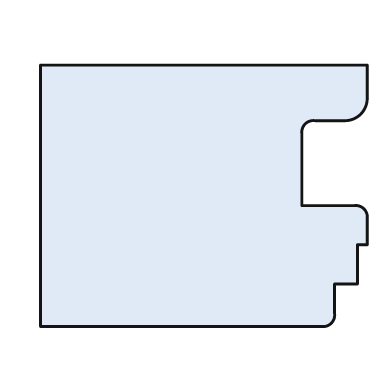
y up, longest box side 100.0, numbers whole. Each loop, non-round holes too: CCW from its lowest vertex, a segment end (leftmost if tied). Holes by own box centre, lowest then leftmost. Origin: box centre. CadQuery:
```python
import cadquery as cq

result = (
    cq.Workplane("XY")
    .moveTo(-50.0, -40.0)
    .lineTo(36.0, -40.0)
    .threePointArc((39.0, -39.0), (40.0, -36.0))
    .lineTo(40.0, -27.0)
    .lineTo(47.0, -27.0)
    .lineTo(47.0, -15.0)
    .lineTo(50.0, -15.0)
    .lineTo(50.0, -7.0)
    .threePointArc((49.0, -4.0), (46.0, -3.0))
    .lineTo(30.0, -3.0)
    .lineTo(30.0, 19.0)
    .threePointArc((31.0, 22.0), (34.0, 23.0))
    .lineTo(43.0, 23.0)
    .threePointArc((48.0, 25.0), (50.0, 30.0))
    .lineTo(50.0, 40.0)
    .lineTo(-50.0, 40.0)
    .close()
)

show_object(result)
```